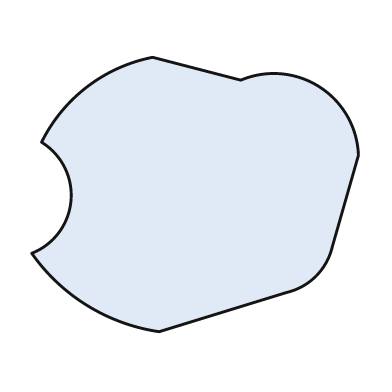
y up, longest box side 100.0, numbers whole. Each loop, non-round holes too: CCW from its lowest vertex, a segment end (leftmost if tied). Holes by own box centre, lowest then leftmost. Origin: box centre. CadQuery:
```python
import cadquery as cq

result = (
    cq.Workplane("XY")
    .moveTo(-11.0, -42.0)
    .lineTo(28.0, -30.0)
    .threePointArc((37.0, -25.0), (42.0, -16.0))
    .lineTo(50.0, 12.0)
    .threePointArc((38.0, 33.0), (14.0, 35.0))
    .lineTo(-13.0, 42.0)
    .threePointArc((-33.0, 33.0), (-47.0, 16.0))
    .threePointArc((-38.0, -2.0), (-50.0, -18.0))
    .threePointArc((-33.0, -34.0), (-11.0, -42.0))
    .close()
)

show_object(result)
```